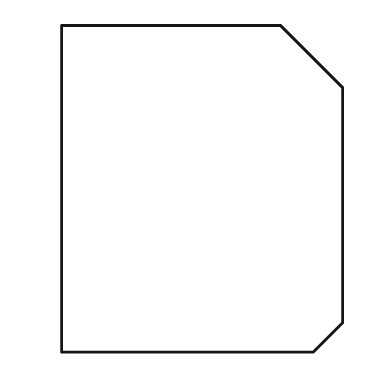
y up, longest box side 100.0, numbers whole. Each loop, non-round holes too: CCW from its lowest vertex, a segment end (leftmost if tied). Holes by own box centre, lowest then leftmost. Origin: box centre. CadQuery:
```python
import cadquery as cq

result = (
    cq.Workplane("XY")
    .moveTo(-43.0, -50.0)
    .lineTo(34.0, -50.0)
    .lineTo(43.0, -41.0)
    .lineTo(43.0, 31.0)
    .lineTo(24.0, 50.0)
    .lineTo(-43.0, 50.0)
    .close()
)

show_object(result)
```